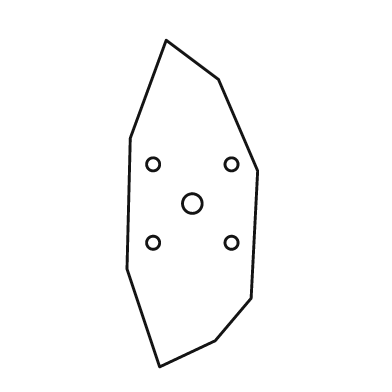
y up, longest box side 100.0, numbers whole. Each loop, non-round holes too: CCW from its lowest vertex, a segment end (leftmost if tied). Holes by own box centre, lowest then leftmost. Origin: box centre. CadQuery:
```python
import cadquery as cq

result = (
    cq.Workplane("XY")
    .moveTo(-10.0, -50.0)
    .lineTo(7.0, -42.0)
    .lineTo(18.0, -29.0)
    .lineTo(20.0, 10.0)
    .lineTo(8.0, 38.0)
    .lineTo(-8.0, 50.0)
    .lineTo(-19.0, 20.0)
    .lineTo(-20.0, -20.0)
    .close()
    .moveTo(-12.0, -12.0)
    .circle(2.0)
    .moveTo(12.0, -12.0)
    .circle(2.0)
    .moveTo(0.0, 0.0)
    .circle(3.0)
    .moveTo(-12.0, 12.0)
    .circle(2.0)
    .moveTo(12.0, 12.0)
    .circle(2.0)
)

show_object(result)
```